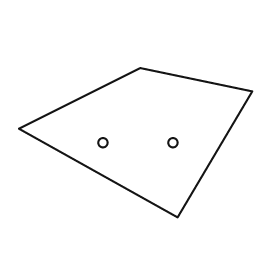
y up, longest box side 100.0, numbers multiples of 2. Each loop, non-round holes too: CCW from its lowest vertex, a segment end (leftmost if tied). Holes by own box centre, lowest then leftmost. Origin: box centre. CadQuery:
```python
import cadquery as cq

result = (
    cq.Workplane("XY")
    .moveTo(18.0, -32.0)
    .lineTo(50.0, 22.0)
    .lineTo(2.0, 32.0)
    .lineTo(-50.0, 6.0)
    .close()
    .moveTo(-14.0, 0.0)
    .circle(2.0)
    .moveTo(16.0, 0.0)
    .circle(2.0)
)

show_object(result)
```